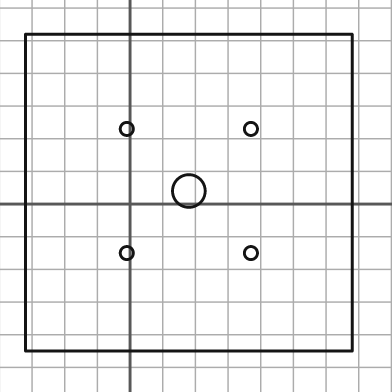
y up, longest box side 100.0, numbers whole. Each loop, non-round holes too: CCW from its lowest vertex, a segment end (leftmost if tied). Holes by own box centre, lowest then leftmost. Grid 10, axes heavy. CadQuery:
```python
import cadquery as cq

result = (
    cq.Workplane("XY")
    .moveTo(-32.0, -45.0)
    .lineTo(68.0, -45.0)
    .lineTo(68.0, 52.0)
    .lineTo(-32.0, 52.0)
    .close()
    .moveTo(-1.0, -15.0)
    .circle(2.0)
    .moveTo(37.0, -15.0)
    .circle(2.0)
    .moveTo(18.0, 4.0)
    .circle(5.0)
    .moveTo(-1.0, 23.0)
    .circle(2.0)
    .moveTo(37.0, 23.0)
    .circle(2.0)
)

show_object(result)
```